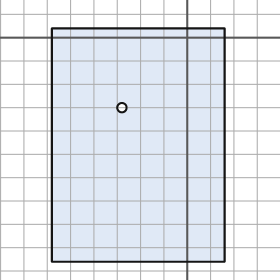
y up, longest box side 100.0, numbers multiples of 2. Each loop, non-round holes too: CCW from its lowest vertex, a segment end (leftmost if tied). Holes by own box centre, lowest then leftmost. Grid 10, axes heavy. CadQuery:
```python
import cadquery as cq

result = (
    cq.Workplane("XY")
    .moveTo(-58.0, -96.0)
    .lineTo(16.0, -96.0)
    .lineTo(16.0, 4.0)
    .lineTo(-58.0, 4.0)
    .close()
    .moveTo(-28.0, -30.0)
    .circle(2.0)
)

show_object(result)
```